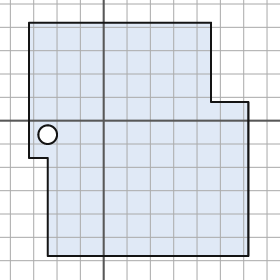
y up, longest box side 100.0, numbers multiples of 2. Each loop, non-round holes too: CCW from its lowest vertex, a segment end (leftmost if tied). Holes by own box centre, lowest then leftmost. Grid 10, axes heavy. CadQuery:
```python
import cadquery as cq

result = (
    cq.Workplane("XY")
    .moveTo(-24.0, -58.0)
    .lineTo(62.0, -58.0)
    .lineTo(62.0, 8.0)
    .lineTo(46.0, 8.0)
    .lineTo(46.0, 42.0)
    .lineTo(-32.0, 42.0)
    .lineTo(-32.0, -16.0)
    .lineTo(-24.0, -16.0)
    .close()
    .moveTo(-24.0, -6.0)
    .circle(4.0)
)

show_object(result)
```